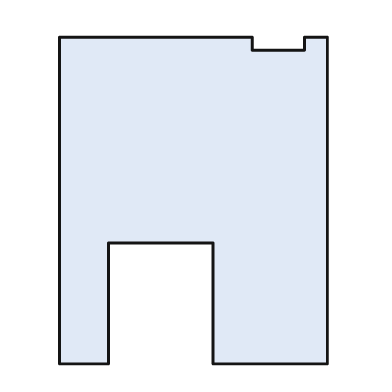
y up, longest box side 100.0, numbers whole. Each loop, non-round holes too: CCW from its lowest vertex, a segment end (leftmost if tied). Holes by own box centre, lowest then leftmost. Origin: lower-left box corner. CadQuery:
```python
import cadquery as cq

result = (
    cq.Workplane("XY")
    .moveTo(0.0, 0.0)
    .lineTo(15.0, 0.0)
    .lineTo(15.0, 37.0)
    .lineTo(47.0, 37.0)
    .lineTo(47.0, 0.0)
    .lineTo(82.0, 0.0)
    .lineTo(82.0, 100.0)
    .lineTo(75.0, 100.0)
    .lineTo(75.0, 96.0)
    .lineTo(59.0, 96.0)
    .lineTo(59.0, 100.0)
    .lineTo(0.0, 100.0)
    .close()
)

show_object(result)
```